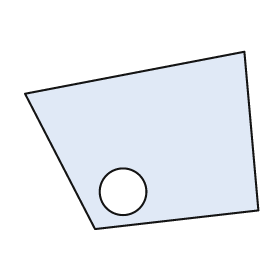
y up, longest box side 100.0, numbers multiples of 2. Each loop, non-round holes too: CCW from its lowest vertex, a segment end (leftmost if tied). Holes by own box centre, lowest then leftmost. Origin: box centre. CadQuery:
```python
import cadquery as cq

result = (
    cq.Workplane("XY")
    .moveTo(-20.0, -38.0)
    .lineTo(50.0, -30.0)
    .lineTo(44.0, 38.0)
    .lineTo(-50.0, 20.0)
    .close()
    .moveTo(-8.0, -22.0)
    .circle(10.0)
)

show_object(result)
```